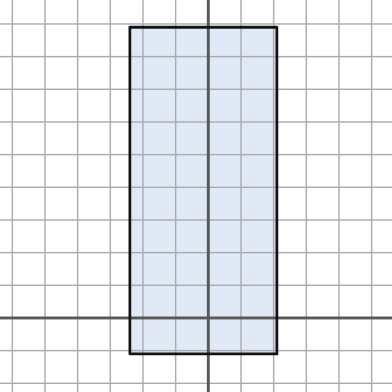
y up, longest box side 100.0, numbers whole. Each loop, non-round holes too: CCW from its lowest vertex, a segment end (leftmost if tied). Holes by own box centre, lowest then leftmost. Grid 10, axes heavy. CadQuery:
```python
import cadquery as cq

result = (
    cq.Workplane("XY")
    .moveTo(-24.0, -11.0)
    .lineTo(21.0, -11.0)
    .lineTo(21.0, 89.0)
    .lineTo(-24.0, 89.0)
    .close()
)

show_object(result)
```